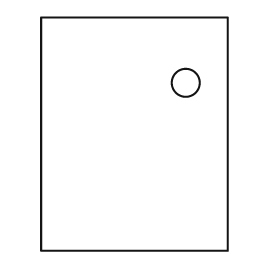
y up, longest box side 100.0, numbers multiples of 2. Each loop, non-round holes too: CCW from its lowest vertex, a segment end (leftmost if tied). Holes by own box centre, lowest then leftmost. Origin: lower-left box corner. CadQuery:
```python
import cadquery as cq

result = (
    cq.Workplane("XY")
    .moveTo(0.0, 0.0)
    .lineTo(80.0, 0.0)
    .lineTo(80.0, 100.0)
    .lineTo(0.0, 100.0)
    .close()
    .moveTo(62.0, 72.0)
    .circle(6.0)
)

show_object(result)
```